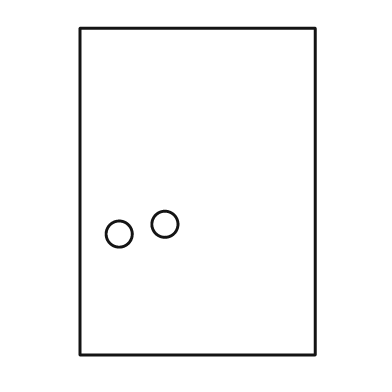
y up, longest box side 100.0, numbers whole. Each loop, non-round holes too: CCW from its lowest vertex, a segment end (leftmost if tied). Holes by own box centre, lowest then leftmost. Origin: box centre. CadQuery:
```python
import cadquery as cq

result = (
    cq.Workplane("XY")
    .moveTo(-36.0, -50.0)
    .lineTo(36.0, -50.0)
    .lineTo(36.0, 50.0)
    .lineTo(-36.0, 50.0)
    .close()
    .moveTo(-24.0, -13.0)
    .circle(4.0)
    .moveTo(-10.0, -10.0)
    .circle(4.0)
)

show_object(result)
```